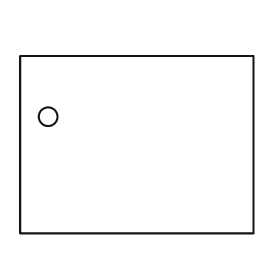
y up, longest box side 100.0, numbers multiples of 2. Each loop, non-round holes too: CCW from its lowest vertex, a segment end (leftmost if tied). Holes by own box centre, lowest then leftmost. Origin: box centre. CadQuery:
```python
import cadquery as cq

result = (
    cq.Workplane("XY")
    .moveTo(-50.0, -38.0)
    .lineTo(50.0, -38.0)
    .lineTo(50.0, 38.0)
    .lineTo(-50.0, 38.0)
    .close()
    .moveTo(-38.0, 12.0)
    .circle(4.0)
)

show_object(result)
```